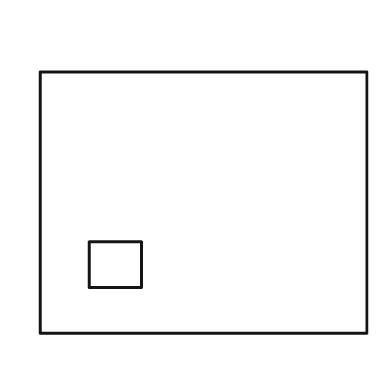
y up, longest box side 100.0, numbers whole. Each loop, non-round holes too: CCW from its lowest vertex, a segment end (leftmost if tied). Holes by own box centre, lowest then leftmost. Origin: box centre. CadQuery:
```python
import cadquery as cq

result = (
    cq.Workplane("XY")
    .moveTo(-50.0, -40.0)
    .lineTo(50.0, -40.0)
    .lineTo(50.0, 40.0)
    .lineTo(-50.0, 40.0)
    .close()
    .moveTo(-35.0, -26.0)
    .lineTo(-19.0, -26.0)
    .lineTo(-19.0, -12.0)
    .lineTo(-35.0, -12.0)
    .close()
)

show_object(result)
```